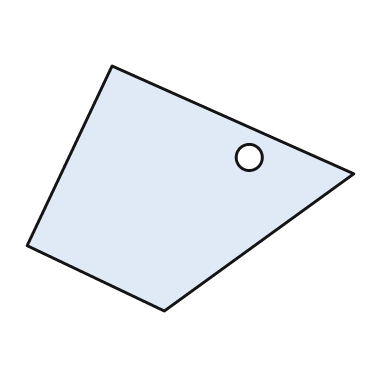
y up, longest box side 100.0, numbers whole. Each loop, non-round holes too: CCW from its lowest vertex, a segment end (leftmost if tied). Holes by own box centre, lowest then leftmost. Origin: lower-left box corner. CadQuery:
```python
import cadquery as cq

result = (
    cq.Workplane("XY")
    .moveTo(42.0, 0.0)
    .lineTo(100.0, 42.0)
    .lineTo(26.0, 75.0)
    .lineTo(0.0, 20.0)
    .close()
    .moveTo(68.0, 47.0)
    .circle(4.0)
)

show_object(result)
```